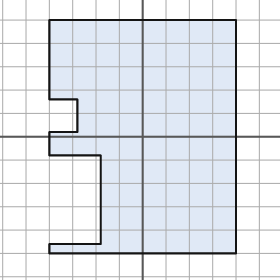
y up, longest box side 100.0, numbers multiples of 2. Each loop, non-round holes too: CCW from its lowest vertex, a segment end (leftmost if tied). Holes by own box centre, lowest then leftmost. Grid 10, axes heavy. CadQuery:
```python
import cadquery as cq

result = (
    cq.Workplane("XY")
    .moveTo(-40.0, -50.0)
    .lineTo(40.0, -50.0)
    .lineTo(40.0, 50.0)
    .lineTo(-40.0, 50.0)
    .lineTo(-40.0, 16.0)
    .lineTo(-28.0, 16.0)
    .lineTo(-28.0, 2.0)
    .lineTo(-40.0, 2.0)
    .lineTo(-40.0, -8.0)
    .lineTo(-18.0, -8.0)
    .lineTo(-18.0, -46.0)
    .lineTo(-40.0, -46.0)
    .close()
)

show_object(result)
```